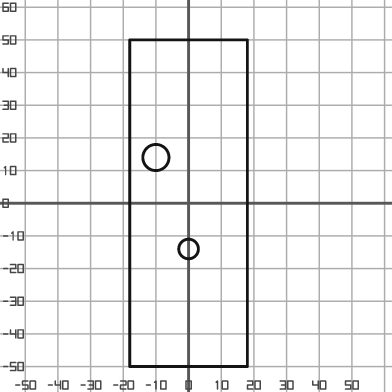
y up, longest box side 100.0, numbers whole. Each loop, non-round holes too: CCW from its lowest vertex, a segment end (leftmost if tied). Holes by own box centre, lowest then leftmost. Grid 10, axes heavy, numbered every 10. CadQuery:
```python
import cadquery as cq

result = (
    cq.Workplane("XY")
    .moveTo(-18.0, -50.0)
    .lineTo(18.0, -50.0)
    .lineTo(18.0, 50.0)
    .lineTo(-18.0, 50.0)
    .close()
    .moveTo(0.0, -14.0)
    .circle(3.0)
    .moveTo(-10.0, 14.0)
    .circle(4.0)
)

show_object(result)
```